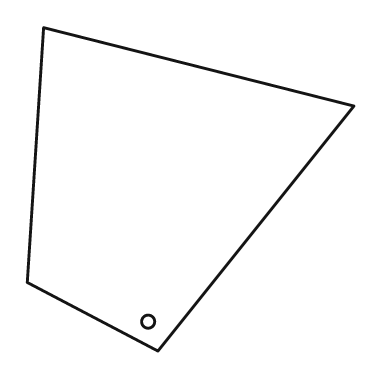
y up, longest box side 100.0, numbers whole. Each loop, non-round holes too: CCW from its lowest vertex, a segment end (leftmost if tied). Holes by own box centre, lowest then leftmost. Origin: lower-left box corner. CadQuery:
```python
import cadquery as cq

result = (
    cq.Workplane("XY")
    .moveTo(40.0, 0.0)
    .lineTo(100.0, 75.0)
    .lineTo(5.0, 99.0)
    .lineTo(0.0, 21.0)
    .close()
    .moveTo(37.0, 9.0)
    .circle(2.0)
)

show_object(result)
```